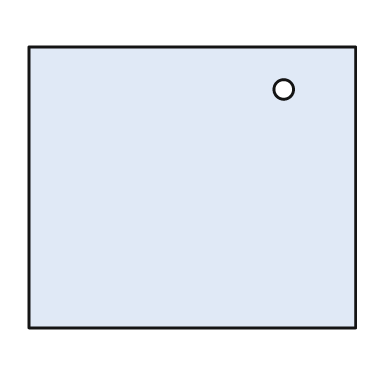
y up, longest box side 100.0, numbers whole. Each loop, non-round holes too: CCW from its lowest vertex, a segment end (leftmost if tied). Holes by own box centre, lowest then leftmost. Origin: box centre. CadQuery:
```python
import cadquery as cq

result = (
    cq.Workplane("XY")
    .moveTo(-50.0, -43.0)
    .lineTo(50.0, -43.0)
    .lineTo(50.0, 43.0)
    .lineTo(-50.0, 43.0)
    .close()
    .moveTo(28.0, 30.0)
    .circle(3.0)
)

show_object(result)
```